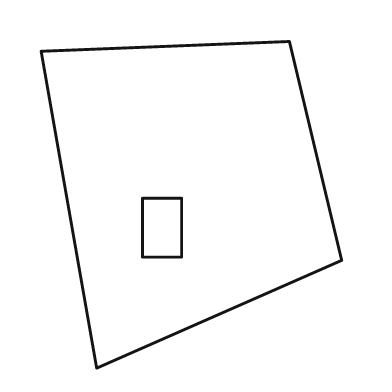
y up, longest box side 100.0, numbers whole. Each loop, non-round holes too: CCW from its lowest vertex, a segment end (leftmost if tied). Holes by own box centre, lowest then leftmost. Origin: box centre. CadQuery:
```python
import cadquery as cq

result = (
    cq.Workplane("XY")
    .moveTo(-29.0, -50.0)
    .lineTo(46.0, -17.0)
    .lineTo(30.0, 50.0)
    .lineTo(-46.0, 47.0)
    .close()
    .moveTo(-15.0, -16.0)
    .lineTo(-3.0, -16.0)
    .lineTo(-3.0, 2.0)
    .lineTo(-15.0, 2.0)
    .close()
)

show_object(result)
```